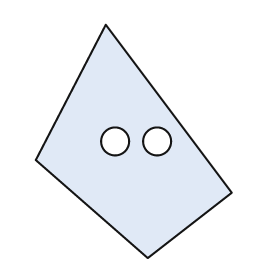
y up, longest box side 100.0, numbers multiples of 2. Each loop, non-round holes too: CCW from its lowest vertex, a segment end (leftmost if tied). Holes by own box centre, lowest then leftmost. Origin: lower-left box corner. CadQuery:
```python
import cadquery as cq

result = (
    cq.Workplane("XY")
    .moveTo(48.0, 0.0)
    .lineTo(84.0, 28.0)
    .lineTo(30.0, 100.0)
    .lineTo(0.0, 42.0)
    .close()
    .moveTo(34.0, 50.0)
    .circle(6.0)
    .moveTo(52.0, 50.0)
    .circle(6.0)
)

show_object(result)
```